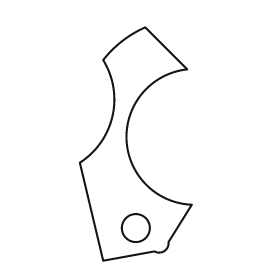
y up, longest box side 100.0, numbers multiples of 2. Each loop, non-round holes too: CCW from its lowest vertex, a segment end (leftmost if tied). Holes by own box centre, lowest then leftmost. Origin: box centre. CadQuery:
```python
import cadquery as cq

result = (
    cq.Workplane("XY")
    .moveTo(-14.0, -50.0)
    .lineTo(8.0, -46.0)
    .threePointArc((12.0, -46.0), (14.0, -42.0))
    .lineTo(24.0, -26.0)
    .threePointArc((-4.0, 2.0), (22.0, 32.0))
    .lineTo(4.0, 50.0)
    .threePointArc((-6.0, 44.0), (-14.0, 36.0))
    .threePointArc((-10.0, 12.0), (-24.0, -8.0))
    .close()
    .moveTo(0.0, -36.0)
    .circle(6.0)
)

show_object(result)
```